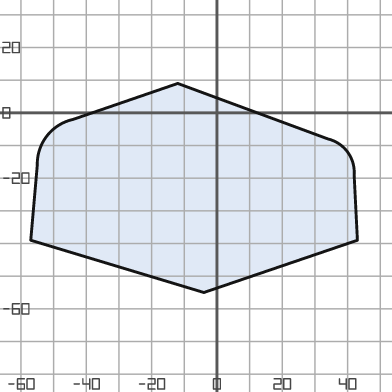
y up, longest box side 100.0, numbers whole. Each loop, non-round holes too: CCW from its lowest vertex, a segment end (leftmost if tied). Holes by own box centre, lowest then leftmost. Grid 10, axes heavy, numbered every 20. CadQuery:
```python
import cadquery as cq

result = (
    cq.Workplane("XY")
    .moveTo(-4.0, -55.0)
    .lineTo(43.0, -39.0)
    .lineTo(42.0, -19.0)
    .threePointArc((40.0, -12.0), (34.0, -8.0))
    .lineTo(-12.0, 9.0)
    .lineTo(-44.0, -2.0)
    .threePointArc((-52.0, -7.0), (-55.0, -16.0))
    .lineTo(-57.0, -39.0)
    .close()
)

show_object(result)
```